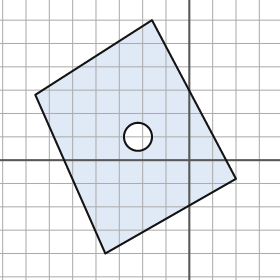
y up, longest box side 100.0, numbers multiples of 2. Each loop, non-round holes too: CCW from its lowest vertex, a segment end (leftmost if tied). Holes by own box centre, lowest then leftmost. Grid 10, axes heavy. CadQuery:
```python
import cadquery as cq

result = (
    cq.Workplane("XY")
    .moveTo(-36.0, -40.0)
    .lineTo(20.0, -8.0)
    .lineTo(-16.0, 60.0)
    .lineTo(-66.0, 28.0)
    .close()
    .moveTo(-22.0, 10.0)
    .circle(6.0)
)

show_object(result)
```